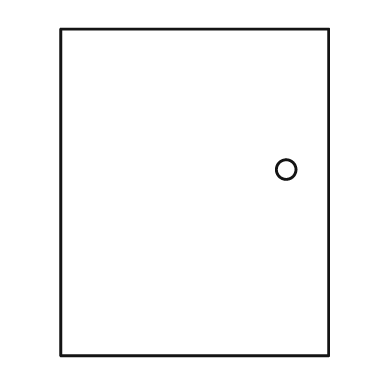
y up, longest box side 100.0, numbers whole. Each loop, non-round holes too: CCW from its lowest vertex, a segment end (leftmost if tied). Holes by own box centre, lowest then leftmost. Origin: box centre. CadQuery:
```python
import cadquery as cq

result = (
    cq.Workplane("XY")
    .moveTo(-41.0, -50.0)
    .lineTo(41.0, -50.0)
    .lineTo(41.0, 50.0)
    .lineTo(-41.0, 50.0)
    .close()
    .moveTo(28.0, 7.0)
    .circle(3.0)
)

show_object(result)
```